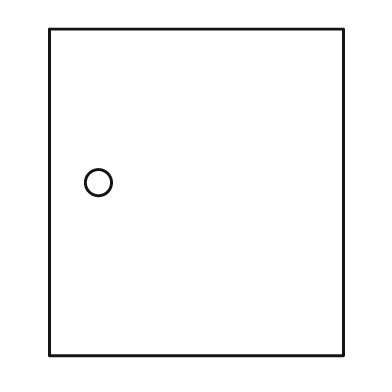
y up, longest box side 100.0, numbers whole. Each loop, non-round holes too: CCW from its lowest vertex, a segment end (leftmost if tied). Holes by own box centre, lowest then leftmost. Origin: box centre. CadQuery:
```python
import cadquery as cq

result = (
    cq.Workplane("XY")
    .moveTo(-45.0, -50.0)
    .lineTo(45.0, -50.0)
    .lineTo(45.0, 50.0)
    .lineTo(-45.0, 50.0)
    .close()
    .moveTo(-30.0, 3.0)
    .circle(4.0)
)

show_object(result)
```